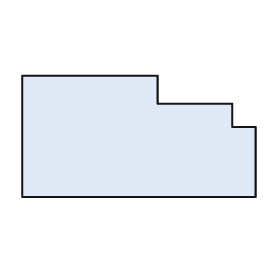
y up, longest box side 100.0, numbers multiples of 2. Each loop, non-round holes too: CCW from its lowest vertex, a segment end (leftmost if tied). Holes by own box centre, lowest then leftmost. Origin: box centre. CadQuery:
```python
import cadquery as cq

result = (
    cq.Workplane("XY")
    .moveTo(-50.0, -26.0)
    .lineTo(50.0, -26.0)
    .lineTo(50.0, 4.0)
    .lineTo(40.0, 4.0)
    .lineTo(40.0, 14.0)
    .lineTo(8.0, 14.0)
    .lineTo(8.0, 26.0)
    .lineTo(-50.0, 26.0)
    .close()
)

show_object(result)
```